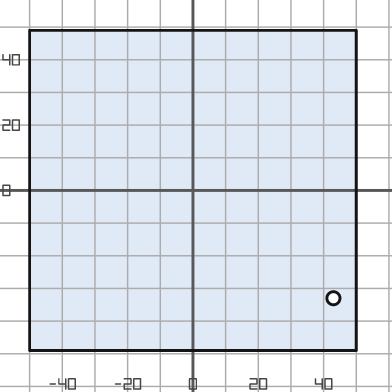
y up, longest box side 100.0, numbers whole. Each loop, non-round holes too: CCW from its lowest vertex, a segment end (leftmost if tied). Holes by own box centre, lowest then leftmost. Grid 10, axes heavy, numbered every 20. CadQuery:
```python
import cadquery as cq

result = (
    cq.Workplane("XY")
    .moveTo(-50.0, -49.0)
    .lineTo(50.0, -49.0)
    .lineTo(50.0, 49.0)
    .lineTo(-50.0, 49.0)
    .close()
    .moveTo(43.0, -33.0)
    .circle(2.0)
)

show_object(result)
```